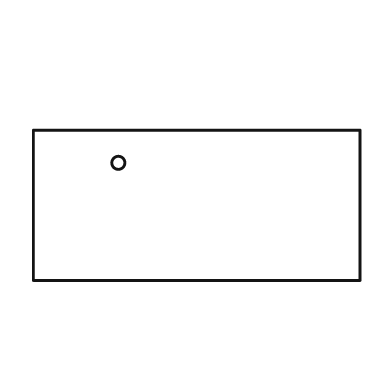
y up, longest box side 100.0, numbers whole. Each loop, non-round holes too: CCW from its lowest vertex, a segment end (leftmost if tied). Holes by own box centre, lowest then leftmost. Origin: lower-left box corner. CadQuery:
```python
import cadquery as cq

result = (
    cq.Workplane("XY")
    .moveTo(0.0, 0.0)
    .lineTo(100.0, 0.0)
    .lineTo(100.0, 46.0)
    .lineTo(0.0, 46.0)
    .close()
    .moveTo(26.0, 36.0)
    .circle(2.0)
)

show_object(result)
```